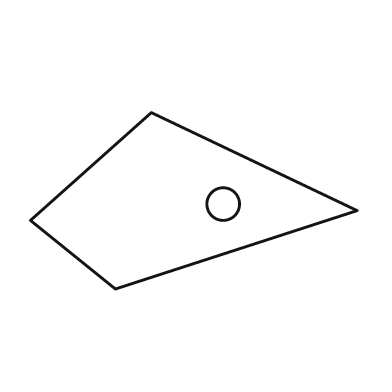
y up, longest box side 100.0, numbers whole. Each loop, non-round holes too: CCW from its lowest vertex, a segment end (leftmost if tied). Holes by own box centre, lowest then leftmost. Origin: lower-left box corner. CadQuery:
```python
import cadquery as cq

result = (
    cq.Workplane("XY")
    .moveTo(26.0, 0.0)
    .lineTo(100.0, 24.0)
    .lineTo(37.0, 54.0)
    .lineTo(0.0, 21.0)
    .close()
    .moveTo(59.0, 26.0)
    .circle(5.0)
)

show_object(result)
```